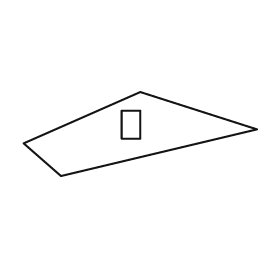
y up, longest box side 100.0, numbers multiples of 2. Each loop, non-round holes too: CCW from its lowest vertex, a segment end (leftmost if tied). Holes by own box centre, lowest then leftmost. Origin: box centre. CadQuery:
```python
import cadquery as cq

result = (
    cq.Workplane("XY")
    .moveTo(-34.0, -18.0)
    .lineTo(50.0, 2.0)
    .lineTo(0.0, 18.0)
    .lineTo(-50.0, -4.0)
    .close()
    .moveTo(-8.0, -2.0)
    .lineTo(0.0, -2.0)
    .lineTo(0.0, 10.0)
    .lineTo(-8.0, 10.0)
    .close()
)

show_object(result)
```